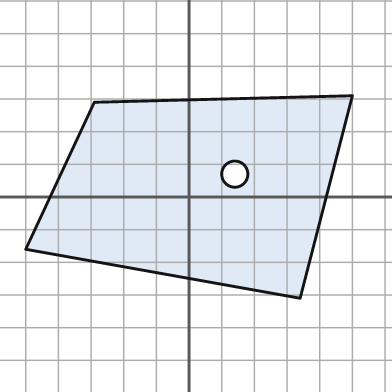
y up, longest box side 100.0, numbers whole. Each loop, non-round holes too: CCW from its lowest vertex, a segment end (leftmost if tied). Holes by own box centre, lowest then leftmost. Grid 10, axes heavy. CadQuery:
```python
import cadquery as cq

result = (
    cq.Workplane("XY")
    .moveTo(34.0, -31.0)
    .lineTo(50.0, 31.0)
    .lineTo(-29.0, 29.0)
    .lineTo(-50.0, -16.0)
    .close()
    .moveTo(14.0, 7.0)
    .circle(4.0)
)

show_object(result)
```